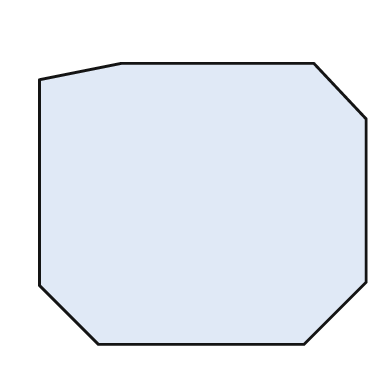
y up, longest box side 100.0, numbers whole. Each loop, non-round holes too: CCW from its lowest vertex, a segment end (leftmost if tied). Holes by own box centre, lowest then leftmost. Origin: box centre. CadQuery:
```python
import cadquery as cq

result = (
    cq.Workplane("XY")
    .moveTo(-32.0, -43.0)
    .lineTo(31.0, -43.0)
    .lineTo(50.0, -24.0)
    .lineTo(50.0, 26.0)
    .lineTo(34.0, 43.0)
    .lineTo(-25.0, 43.0)
    .lineTo(-50.0, 38.0)
    .lineTo(-50.0, -25.0)
    .close()
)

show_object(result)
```